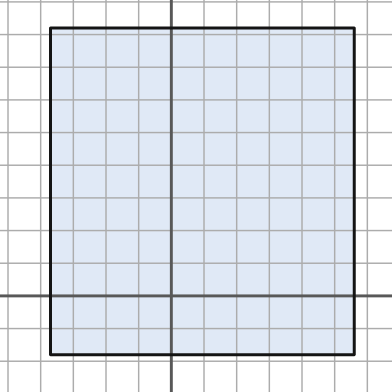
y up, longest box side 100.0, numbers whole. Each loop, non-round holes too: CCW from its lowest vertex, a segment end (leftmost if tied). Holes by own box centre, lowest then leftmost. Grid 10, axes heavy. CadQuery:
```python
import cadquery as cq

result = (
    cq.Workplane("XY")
    .moveTo(-37.0, -18.0)
    .lineTo(56.0, -18.0)
    .lineTo(56.0, 82.0)
    .lineTo(-37.0, 82.0)
    .close()
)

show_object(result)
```